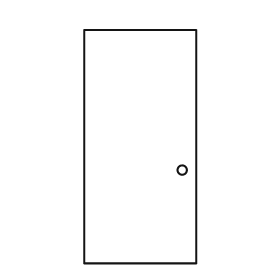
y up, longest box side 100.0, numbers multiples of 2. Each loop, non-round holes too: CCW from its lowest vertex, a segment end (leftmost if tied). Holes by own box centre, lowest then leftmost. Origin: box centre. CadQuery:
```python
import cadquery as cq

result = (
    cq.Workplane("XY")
    .moveTo(-24.0, -50.0)
    .lineTo(24.0, -50.0)
    .lineTo(24.0, 50.0)
    .lineTo(-24.0, 50.0)
    .close()
    .moveTo(18.0, -10.0)
    .circle(2.0)
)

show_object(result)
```